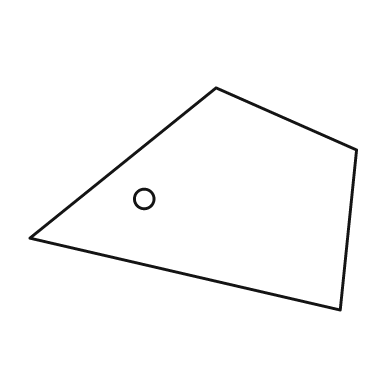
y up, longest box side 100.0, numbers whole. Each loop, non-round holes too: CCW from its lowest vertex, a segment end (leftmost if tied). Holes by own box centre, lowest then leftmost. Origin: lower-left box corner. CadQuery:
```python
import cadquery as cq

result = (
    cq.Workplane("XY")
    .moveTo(95.0, 0.0)
    .lineTo(100.0, 49.0)
    .lineTo(57.0, 68.0)
    .lineTo(0.0, 22.0)
    .close()
    .moveTo(35.0, 34.0)
    .circle(3.0)
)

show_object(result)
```